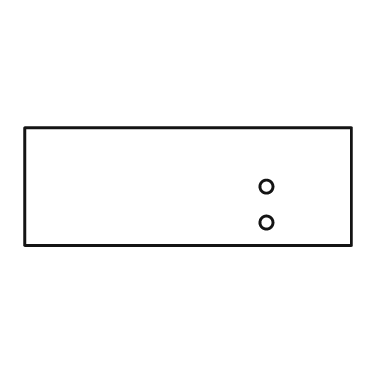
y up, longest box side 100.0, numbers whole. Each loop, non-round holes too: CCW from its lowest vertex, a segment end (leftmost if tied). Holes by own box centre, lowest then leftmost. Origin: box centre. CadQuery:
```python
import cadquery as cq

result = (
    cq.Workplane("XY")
    .moveTo(-50.0, -18.0)
    .lineTo(50.0, -18.0)
    .lineTo(50.0, 18.0)
    .lineTo(-50.0, 18.0)
    .close()
    .moveTo(24.0, -11.0)
    .circle(2.0)
    .moveTo(24.0, 0.0)
    .circle(2.0)
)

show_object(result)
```